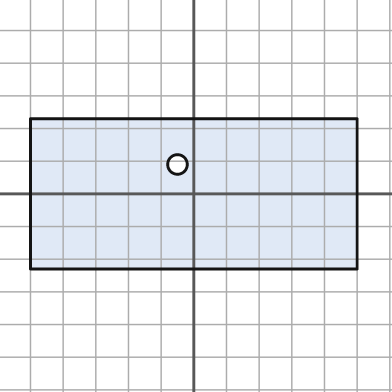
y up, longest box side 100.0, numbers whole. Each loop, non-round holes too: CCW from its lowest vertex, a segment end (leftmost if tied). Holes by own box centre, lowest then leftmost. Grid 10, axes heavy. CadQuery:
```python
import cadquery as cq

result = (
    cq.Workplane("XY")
    .moveTo(-50.0, -23.0)
    .lineTo(50.0, -23.0)
    .lineTo(50.0, 23.0)
    .lineTo(-50.0, 23.0)
    .close()
    .moveTo(-5.0, 9.0)
    .circle(3.0)
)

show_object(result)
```